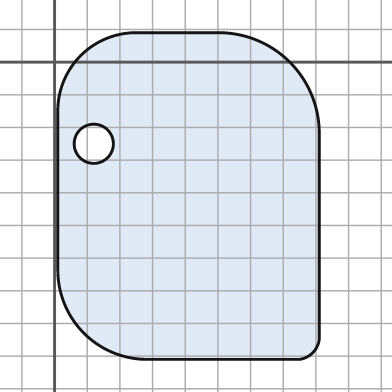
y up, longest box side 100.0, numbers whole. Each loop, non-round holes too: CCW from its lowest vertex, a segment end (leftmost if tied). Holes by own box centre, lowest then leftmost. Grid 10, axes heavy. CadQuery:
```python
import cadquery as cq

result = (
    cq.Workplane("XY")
    .moveTo(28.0, -91.0)
    .lineTo(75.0, -91.0)
    .threePointArc((79.0, -89.0), (81.0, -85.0))
    .lineTo(81.0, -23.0)
    .threePointArc((72.0, 0.0), (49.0, 9.0))
    .lineTo(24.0, 9.0)
    .threePointArc((8.0, 2.0), (1.0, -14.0))
    .lineTo(1.0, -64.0)
    .threePointArc((9.0, -83.0), (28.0, -91.0))
    .close()
    .moveTo(12.0, -25.0)
    .circle(6.0)
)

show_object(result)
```